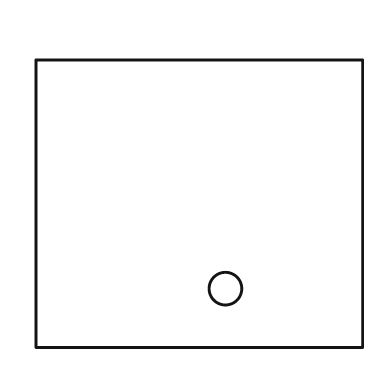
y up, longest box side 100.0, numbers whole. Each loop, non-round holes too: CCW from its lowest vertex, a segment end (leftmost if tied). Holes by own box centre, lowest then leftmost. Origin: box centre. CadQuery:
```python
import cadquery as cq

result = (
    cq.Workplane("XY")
    .moveTo(-50.0, -44.0)
    .lineTo(50.0, -44.0)
    .lineTo(50.0, 44.0)
    .lineTo(-50.0, 44.0)
    .close()
    .moveTo(8.0, -26.0)
    .circle(5.0)
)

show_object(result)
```